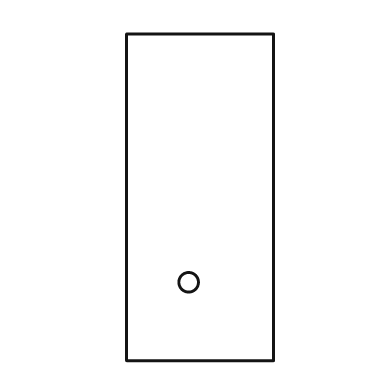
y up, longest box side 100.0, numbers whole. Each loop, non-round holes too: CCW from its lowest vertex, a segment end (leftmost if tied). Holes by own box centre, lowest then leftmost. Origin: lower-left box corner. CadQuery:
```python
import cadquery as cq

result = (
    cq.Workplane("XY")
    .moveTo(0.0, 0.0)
    .lineTo(45.0, 0.0)
    .lineTo(45.0, 100.0)
    .lineTo(0.0, 100.0)
    .close()
    .moveTo(19.0, 24.0)
    .circle(3.0)
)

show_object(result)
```